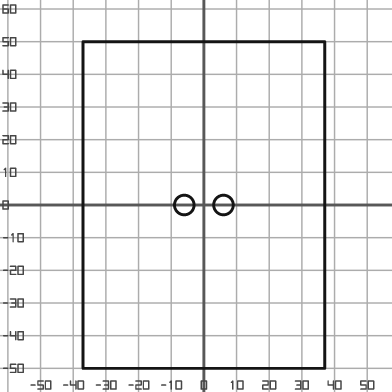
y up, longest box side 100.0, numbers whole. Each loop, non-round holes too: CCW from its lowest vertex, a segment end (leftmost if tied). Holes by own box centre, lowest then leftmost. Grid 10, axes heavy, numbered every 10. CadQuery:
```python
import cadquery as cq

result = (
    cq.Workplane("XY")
    .moveTo(-37.0, -50.0)
    .lineTo(37.0, -50.0)
    .lineTo(37.0, 50.0)
    .lineTo(-37.0, 50.0)
    .close()
    .moveTo(-6.0, 0.0)
    .circle(3.0)
    .moveTo(6.0, 0.0)
    .circle(3.0)
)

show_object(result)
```